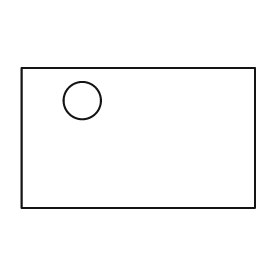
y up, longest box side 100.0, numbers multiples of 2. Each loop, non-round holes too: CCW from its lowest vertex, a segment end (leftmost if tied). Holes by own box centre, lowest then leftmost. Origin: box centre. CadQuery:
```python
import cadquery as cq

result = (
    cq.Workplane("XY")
    .moveTo(-50.0, -30.0)
    .lineTo(50.0, -30.0)
    .lineTo(50.0, 30.0)
    .lineTo(-50.0, 30.0)
    .close()
    .moveTo(-24.0, 16.0)
    .circle(8.0)
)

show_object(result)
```